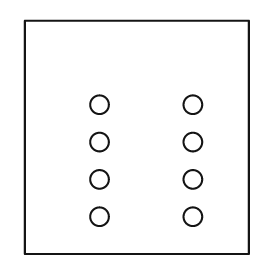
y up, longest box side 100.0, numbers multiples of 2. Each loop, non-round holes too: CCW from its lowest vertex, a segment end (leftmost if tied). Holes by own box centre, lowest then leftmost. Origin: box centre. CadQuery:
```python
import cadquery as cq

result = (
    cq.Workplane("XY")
    .moveTo(-48.0, -50.0)
    .lineTo(48.0, -50.0)
    .lineTo(48.0, 50.0)
    .lineTo(-48.0, 50.0)
    .close()
    .moveTo(-16.0, -34.0)
    .circle(4.0)
    .moveTo(24.0, -34.0)
    .circle(4.0)
    .moveTo(-16.0, -18.0)
    .circle(4.0)
    .moveTo(24.0, -18.0)
    .circle(4.0)
    .moveTo(-16.0, -2.0)
    .circle(4.0)
    .moveTo(24.0, -2.0)
    .circle(4.0)
    .moveTo(-16.0, 14.0)
    .circle(4.0)
    .moveTo(24.0, 14.0)
    .circle(4.0)
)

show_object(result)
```